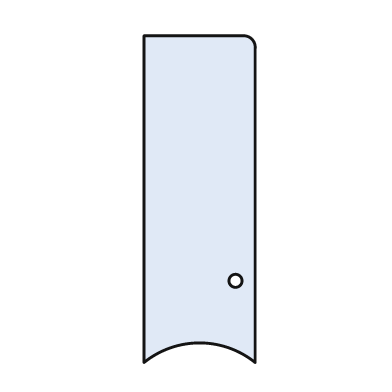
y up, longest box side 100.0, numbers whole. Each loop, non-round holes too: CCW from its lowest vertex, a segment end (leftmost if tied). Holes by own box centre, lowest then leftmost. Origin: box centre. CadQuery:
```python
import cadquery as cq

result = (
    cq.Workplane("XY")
    .moveTo(-17.0, -50.0)
    .threePointArc((0.0, -44.0), (17.0, -50.0))
    .lineTo(17.0, 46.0)
    .threePointArc((16.0, 49.0), (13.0, 50.0))
    .lineTo(-17.0, 50.0)
    .close()
    .moveTo(11.0, -25.0)
    .circle(2.0)
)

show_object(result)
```